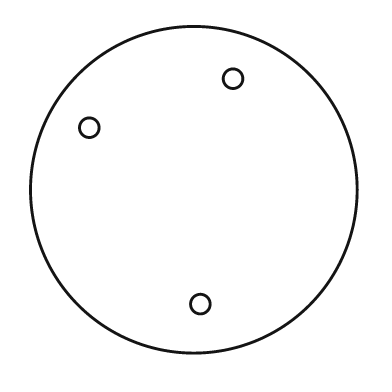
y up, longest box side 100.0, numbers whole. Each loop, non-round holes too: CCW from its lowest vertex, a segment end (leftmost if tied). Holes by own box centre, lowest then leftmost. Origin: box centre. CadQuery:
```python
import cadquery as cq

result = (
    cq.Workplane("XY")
    .moveTo(0.0, 0.0)
    .circle(50.0)
    .moveTo(2.0, -35.0)
    .circle(3.0)
    .moveTo(-32.0, 19.0)
    .circle(3.0)
    .moveTo(12.0, 34.0)
    .circle(3.0)
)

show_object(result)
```